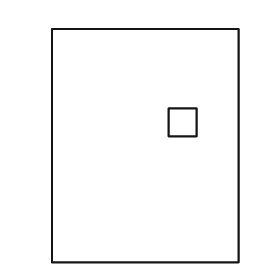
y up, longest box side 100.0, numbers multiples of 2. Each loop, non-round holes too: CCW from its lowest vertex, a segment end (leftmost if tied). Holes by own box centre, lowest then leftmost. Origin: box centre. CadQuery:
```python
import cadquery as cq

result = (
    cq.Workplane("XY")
    .moveTo(-40.0, -50.0)
    .lineTo(40.0, -50.0)
    .lineTo(40.0, 50.0)
    .lineTo(-40.0, 50.0)
    .close()
    .moveTo(10.0, 4.0)
    .lineTo(22.0, 4.0)
    .lineTo(22.0, 16.0)
    .lineTo(10.0, 16.0)
    .close()
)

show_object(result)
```